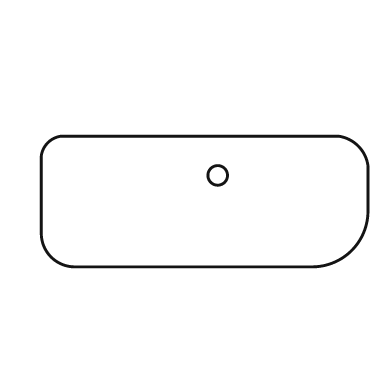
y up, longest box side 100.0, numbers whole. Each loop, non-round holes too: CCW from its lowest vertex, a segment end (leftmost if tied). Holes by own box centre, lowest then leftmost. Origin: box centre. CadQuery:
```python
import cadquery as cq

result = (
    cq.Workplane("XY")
    .moveTo(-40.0, -20.0)
    .lineTo(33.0, -20.0)
    .threePointArc((45.0, -15.0), (50.0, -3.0))
    .lineTo(50.0, 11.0)
    .threePointArc((47.0, 17.0), (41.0, 20.0))
    .lineTo(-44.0, 20.0)
    .threePointArc((-48.0, 18.0), (-50.0, 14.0))
    .lineTo(-50.0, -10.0)
    .threePointArc((-47.0, -17.0), (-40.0, -20.0))
    .close()
    .moveTo(4.0, 8.0)
    .circle(3.0)
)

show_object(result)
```